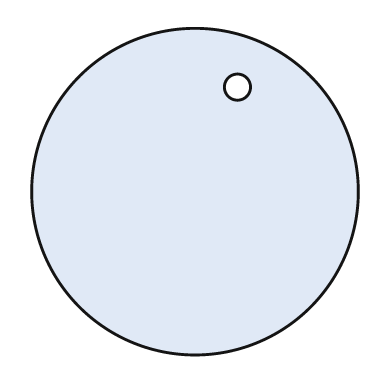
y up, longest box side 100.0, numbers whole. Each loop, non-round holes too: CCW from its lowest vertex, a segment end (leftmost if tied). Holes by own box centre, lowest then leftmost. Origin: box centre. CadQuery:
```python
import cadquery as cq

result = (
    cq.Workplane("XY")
    .moveTo(0.0, 0.0)
    .circle(50.0)
    .moveTo(13.0, 32.0)
    .circle(4.0)
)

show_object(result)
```